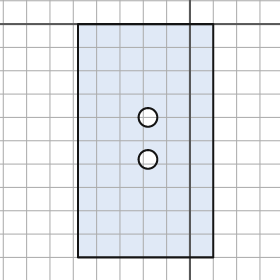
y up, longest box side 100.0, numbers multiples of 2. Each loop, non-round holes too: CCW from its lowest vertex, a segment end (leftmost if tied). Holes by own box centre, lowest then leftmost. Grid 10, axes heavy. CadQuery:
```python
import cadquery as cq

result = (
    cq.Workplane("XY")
    .moveTo(-48.0, -100.0)
    .lineTo(10.0, -100.0)
    .lineTo(10.0, 0.0)
    .lineTo(-48.0, 0.0)
    .close()
    .moveTo(-18.0, -58.0)
    .circle(4.0)
    .moveTo(-18.0, -40.0)
    .circle(4.0)
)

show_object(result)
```